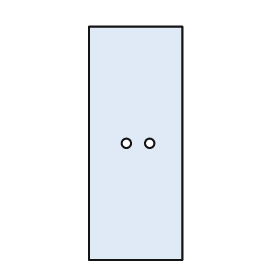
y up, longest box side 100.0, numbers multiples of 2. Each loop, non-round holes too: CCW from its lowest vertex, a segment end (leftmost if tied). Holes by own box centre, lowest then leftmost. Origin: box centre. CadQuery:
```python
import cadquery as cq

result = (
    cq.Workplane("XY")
    .moveTo(-20.0, -50.0)
    .lineTo(20.0, -50.0)
    .lineTo(20.0, 50.0)
    .lineTo(-20.0, 50.0)
    .close()
    .moveTo(-4.0, 0.0)
    .circle(2.0)
    .moveTo(6.0, 0.0)
    .circle(2.0)
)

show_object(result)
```